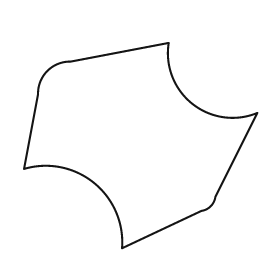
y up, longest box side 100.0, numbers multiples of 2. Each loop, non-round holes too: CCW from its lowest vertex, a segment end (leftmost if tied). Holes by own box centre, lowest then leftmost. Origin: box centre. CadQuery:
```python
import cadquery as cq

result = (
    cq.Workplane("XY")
    .moveTo(-8.0, -44.0)
    .lineTo(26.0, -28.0)
    .threePointArc((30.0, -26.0), (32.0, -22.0))
    .lineTo(50.0, 14.0)
    .threePointArc((22.0, 18.0), (12.0, 44.0))
    .lineTo(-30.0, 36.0)
    .threePointArc((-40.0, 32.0), (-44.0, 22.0))
    .lineTo(-50.0, -10.0)
    .threePointArc((-20.0, -16.0), (-8.0, -44.0))
    .close()
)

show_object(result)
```